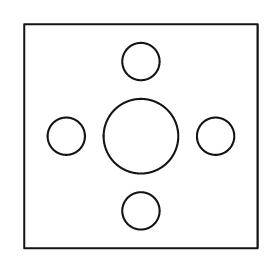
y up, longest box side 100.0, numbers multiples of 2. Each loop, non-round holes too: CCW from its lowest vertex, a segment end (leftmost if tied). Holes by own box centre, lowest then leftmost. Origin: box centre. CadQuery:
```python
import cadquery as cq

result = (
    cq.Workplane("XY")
    .moveTo(-50.0, -48.0)
    .lineTo(50.0, -48.0)
    .lineTo(50.0, 48.0)
    .lineTo(-50.0, 48.0)
    .close()
    .moveTo(0.0, -32.0)
    .circle(8.0)
    .moveTo(-32.0, 0.0)
    .circle(8.0)
    .moveTo(0.0, 0.0)
    .circle(16.0)
    .moveTo(32.0, 0.0)
    .circle(8.0)
    .moveTo(0.0, 32.0)
    .circle(8.0)
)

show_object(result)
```